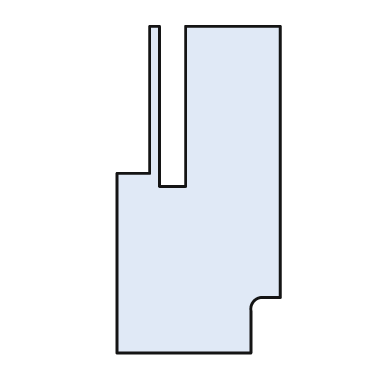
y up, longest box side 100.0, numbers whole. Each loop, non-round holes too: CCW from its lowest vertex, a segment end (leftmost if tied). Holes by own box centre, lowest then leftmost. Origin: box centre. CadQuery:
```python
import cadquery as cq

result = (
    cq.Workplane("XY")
    .moveTo(-25.0, -50.0)
    .lineTo(16.0, -50.0)
    .lineTo(16.0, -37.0)
    .threePointArc((17.0, -34.0), (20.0, -33.0))
    .lineTo(25.0, -33.0)
    .lineTo(25.0, 50.0)
    .lineTo(-4.0, 50.0)
    .lineTo(-4.0, 1.0)
    .lineTo(-12.0, 1.0)
    .lineTo(-12.0, 50.0)
    .lineTo(-15.0, 50.0)
    .lineTo(-15.0, 5.0)
    .lineTo(-25.0, 5.0)
    .close()
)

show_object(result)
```